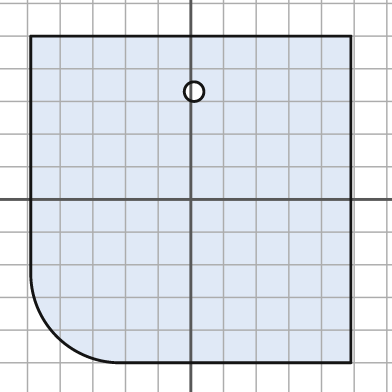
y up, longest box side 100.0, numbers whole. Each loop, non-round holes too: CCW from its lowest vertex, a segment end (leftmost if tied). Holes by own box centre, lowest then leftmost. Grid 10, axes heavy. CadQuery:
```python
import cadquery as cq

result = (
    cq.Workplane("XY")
    .moveTo(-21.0, -50.0)
    .lineTo(49.0, -50.0)
    .lineTo(49.0, 50.0)
    .lineTo(-49.0, 50.0)
    .lineTo(-49.0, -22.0)
    .threePointArc((-41.0, -42.0), (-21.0, -50.0))
    .close()
    .moveTo(1.0, 33.0)
    .circle(3.0)
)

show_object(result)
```